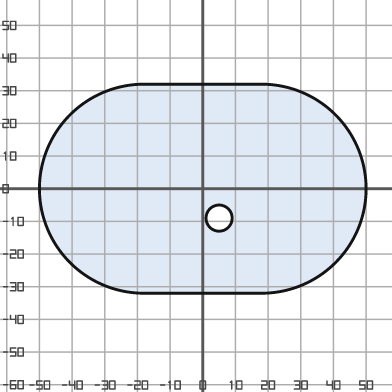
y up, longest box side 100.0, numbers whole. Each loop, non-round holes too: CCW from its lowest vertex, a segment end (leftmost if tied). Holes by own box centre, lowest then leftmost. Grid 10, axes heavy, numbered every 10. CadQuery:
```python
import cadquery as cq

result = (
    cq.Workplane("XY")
    .moveTo(-18.0, -32.0)
    .lineTo(18.0, -32.0)
    .threePointArc((50.0, 0.0), (18.0, 32.0))
    .lineTo(-18.0, 32.0)
    .threePointArc((-50.0, 0.0), (-18.0, -32.0))
    .close()
    .moveTo(5.0, -9.0)
    .circle(4.0)
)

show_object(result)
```